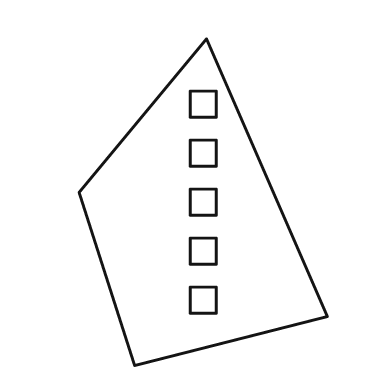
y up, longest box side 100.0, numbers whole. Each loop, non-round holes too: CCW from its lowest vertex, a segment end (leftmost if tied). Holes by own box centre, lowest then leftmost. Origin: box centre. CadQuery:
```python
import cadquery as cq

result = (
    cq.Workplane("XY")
    .moveTo(-21.0, -50.0)
    .lineTo(38.0, -35.0)
    .lineTo(1.0, 50.0)
    .lineTo(-38.0, 3.0)
    .close()
    .moveTo(-4.0, -34.0)
    .lineTo(4.0, -34.0)
    .lineTo(4.0, -26.0)
    .lineTo(-4.0, -26.0)
    .close()
    .moveTo(-4.0, -19.0)
    .lineTo(4.0, -19.0)
    .lineTo(4.0, -11.0)
    .lineTo(-4.0, -11.0)
    .close()
    .moveTo(-4.0, -4.0)
    .lineTo(4.0, -4.0)
    .lineTo(4.0, 4.0)
    .lineTo(-4.0, 4.0)
    .close()
    .moveTo(-4.0, 11.0)
    .lineTo(4.0, 11.0)
    .lineTo(4.0, 19.0)
    .lineTo(-4.0, 19.0)
    .close()
    .moveTo(-4.0, 26.0)
    .lineTo(4.0, 26.0)
    .lineTo(4.0, 34.0)
    .lineTo(-4.0, 34.0)
    .close()
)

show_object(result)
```